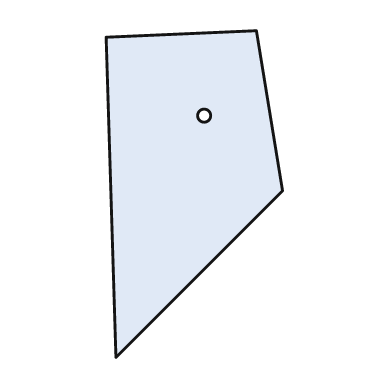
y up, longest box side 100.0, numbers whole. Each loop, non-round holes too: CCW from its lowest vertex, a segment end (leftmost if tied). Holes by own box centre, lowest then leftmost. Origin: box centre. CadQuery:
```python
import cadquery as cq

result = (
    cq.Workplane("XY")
    .moveTo(-24.0, -50.0)
    .lineTo(27.0, 1.0)
    .lineTo(19.0, 50.0)
    .lineTo(-27.0, 48.0)
    .close()
    .moveTo(3.0, 24.0)
    .circle(2.0)
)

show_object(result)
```